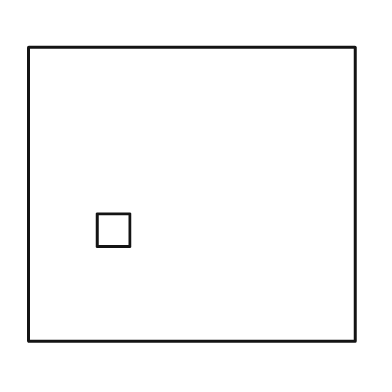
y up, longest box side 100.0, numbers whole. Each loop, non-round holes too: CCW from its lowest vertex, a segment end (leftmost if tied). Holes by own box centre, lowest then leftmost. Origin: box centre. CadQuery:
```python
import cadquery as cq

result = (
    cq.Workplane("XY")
    .moveTo(-50.0, -45.0)
    .lineTo(50.0, -45.0)
    .lineTo(50.0, 45.0)
    .lineTo(-50.0, 45.0)
    .close()
    .moveTo(-29.0, -16.0)
    .lineTo(-19.0, -16.0)
    .lineTo(-19.0, -6.0)
    .lineTo(-29.0, -6.0)
    .close()
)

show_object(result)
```